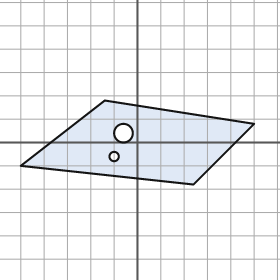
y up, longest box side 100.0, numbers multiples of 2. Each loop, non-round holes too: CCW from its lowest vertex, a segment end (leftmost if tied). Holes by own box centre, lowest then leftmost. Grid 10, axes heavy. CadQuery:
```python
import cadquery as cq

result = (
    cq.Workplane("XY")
    .moveTo(24.0, -18.0)
    .lineTo(50.0, 8.0)
    .lineTo(-14.0, 18.0)
    .lineTo(-50.0, -10.0)
    .close()
    .moveTo(-10.0, -6.0)
    .circle(2.0)
    .moveTo(-6.0, 4.0)
    .circle(4.0)
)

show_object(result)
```